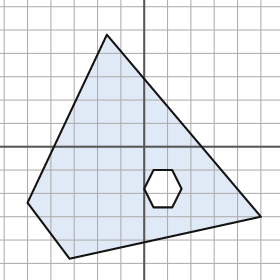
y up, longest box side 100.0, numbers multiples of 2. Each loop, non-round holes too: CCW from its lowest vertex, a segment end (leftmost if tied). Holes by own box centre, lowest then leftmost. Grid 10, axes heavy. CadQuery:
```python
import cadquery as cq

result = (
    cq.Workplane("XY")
    .moveTo(-32.0, -48.0)
    .lineTo(50.0, -30.0)
    .lineTo(-16.0, 48.0)
    .lineTo(-50.0, -24.0)
    .close()
    .moveTo(4.0, -26.0)
    .lineTo(12.0, -26.0)
    .lineTo(16.0, -18.0)
    .lineTo(12.0, -10.0)
    .lineTo(4.0, -10.0)
    .lineTo(0.0, -18.0)
    .close()
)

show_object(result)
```